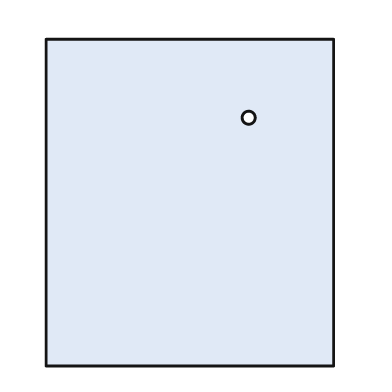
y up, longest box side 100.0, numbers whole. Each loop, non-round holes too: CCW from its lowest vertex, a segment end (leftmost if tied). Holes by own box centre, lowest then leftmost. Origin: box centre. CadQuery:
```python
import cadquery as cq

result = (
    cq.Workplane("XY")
    .moveTo(-44.0, -50.0)
    .lineTo(44.0, -50.0)
    .lineTo(44.0, 50.0)
    .lineTo(-44.0, 50.0)
    .close()
    .moveTo(18.0, 26.0)
    .circle(2.0)
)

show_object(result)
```